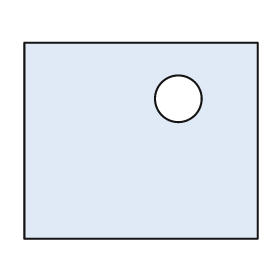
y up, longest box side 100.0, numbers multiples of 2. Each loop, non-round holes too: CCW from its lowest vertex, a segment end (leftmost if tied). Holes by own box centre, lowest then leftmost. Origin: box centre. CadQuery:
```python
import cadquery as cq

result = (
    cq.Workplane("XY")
    .moveTo(-50.0, -42.0)
    .lineTo(50.0, -42.0)
    .lineTo(50.0, 42.0)
    .lineTo(-50.0, 42.0)
    .close()
    .moveTo(16.0, 18.0)
    .circle(10.0)
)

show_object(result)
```